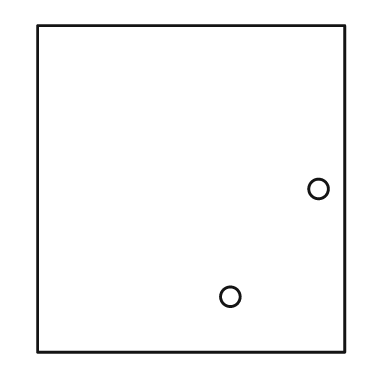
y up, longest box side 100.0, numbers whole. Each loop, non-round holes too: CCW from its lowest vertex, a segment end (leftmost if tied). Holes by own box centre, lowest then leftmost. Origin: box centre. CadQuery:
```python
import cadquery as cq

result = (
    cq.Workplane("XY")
    .moveTo(-47.0, -50.0)
    .lineTo(47.0, -50.0)
    .lineTo(47.0, 50.0)
    .lineTo(-47.0, 50.0)
    .close()
    .moveTo(12.0, -33.0)
    .circle(3.0)
    .moveTo(39.0, 0.0)
    .circle(3.0)
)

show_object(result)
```